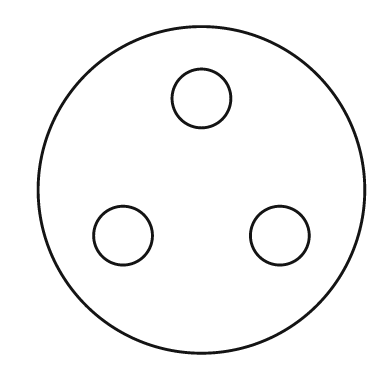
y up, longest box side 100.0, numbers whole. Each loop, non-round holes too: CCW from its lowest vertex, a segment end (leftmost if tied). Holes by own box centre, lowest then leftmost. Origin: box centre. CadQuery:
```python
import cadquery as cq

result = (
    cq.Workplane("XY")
    .moveTo(0.0, 0.0)
    .circle(50.0)
    .moveTo(-24.0, -14.0)
    .circle(9.0)
    .moveTo(24.0, -14.0)
    .circle(9.0)
    .moveTo(0.0, 28.0)
    .circle(9.0)
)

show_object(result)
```